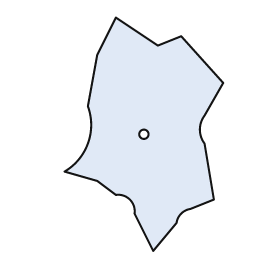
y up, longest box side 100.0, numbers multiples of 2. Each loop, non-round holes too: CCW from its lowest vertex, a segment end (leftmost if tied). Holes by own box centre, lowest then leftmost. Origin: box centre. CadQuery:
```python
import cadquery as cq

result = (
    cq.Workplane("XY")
    .moveTo(4.0, -50.0)
    .lineTo(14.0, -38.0)
    .threePointArc((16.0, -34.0), (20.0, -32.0))
    .lineTo(30.0, -28.0)
    .lineTo(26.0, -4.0)
    .threePointArc((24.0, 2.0), (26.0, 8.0))
    .lineTo(34.0, 22.0)
    .lineTo(16.0, 42.0)
    .lineTo(6.0, 38.0)
    .lineTo(-12.0, 50.0)
    .lineTo(-20.0, 34.0)
    .lineTo(-24.0, 12.0)
    .threePointArc((-24.0, -4.0), (-34.0, -16.0))
    .lineTo(-20.0, -20.0)
    .lineTo(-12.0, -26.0)
    .threePointArc((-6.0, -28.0), (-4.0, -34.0))
    .close()
    .moveTo(0.0, 0.0)
    .circle(2.0)
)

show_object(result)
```